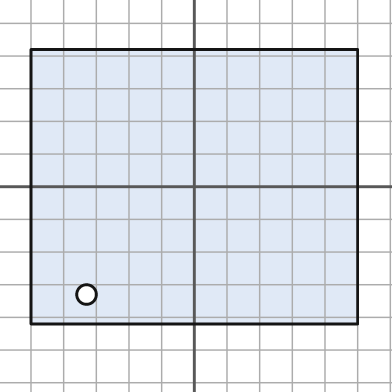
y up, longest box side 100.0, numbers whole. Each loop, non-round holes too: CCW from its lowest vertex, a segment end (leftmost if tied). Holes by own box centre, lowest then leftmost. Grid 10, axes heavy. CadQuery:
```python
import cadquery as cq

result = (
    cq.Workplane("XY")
    .moveTo(-50.0, -42.0)
    .lineTo(50.0, -42.0)
    .lineTo(50.0, 42.0)
    .lineTo(-50.0, 42.0)
    .close()
    .moveTo(-33.0, -33.0)
    .circle(3.0)
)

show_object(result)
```